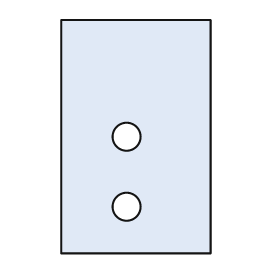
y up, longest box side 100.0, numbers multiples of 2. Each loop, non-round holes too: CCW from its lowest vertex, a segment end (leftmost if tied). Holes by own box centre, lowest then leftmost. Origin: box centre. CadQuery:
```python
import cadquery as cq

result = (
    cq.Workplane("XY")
    .moveTo(-32.0, -50.0)
    .lineTo(32.0, -50.0)
    .lineTo(32.0, 50.0)
    .lineTo(-32.0, 50.0)
    .close()
    .moveTo(-4.0, -30.0)
    .circle(6.0)
    .moveTo(-4.0, 0.0)
    .circle(6.0)
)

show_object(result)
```